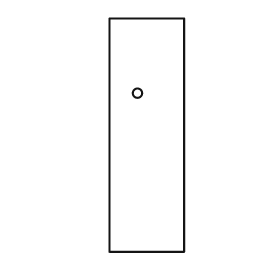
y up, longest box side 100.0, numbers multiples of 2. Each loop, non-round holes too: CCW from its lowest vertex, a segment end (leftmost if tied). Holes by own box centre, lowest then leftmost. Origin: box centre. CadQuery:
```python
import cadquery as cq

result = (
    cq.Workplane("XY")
    .moveTo(-16.0, -50.0)
    .lineTo(16.0, -50.0)
    .lineTo(16.0, 50.0)
    .lineTo(-16.0, 50.0)
    .close()
    .moveTo(-4.0, 18.0)
    .circle(2.0)
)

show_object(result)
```